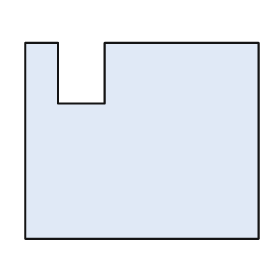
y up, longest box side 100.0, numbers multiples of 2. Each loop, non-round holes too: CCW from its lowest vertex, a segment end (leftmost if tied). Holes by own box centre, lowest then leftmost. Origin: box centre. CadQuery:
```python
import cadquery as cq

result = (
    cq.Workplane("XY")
    .moveTo(-50.0, -42.0)
    .lineTo(50.0, -42.0)
    .lineTo(50.0, 42.0)
    .lineTo(-16.0, 42.0)
    .lineTo(-16.0, 16.0)
    .lineTo(-36.0, 16.0)
    .lineTo(-36.0, 42.0)
    .lineTo(-50.0, 42.0)
    .close()
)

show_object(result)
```